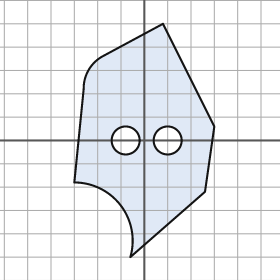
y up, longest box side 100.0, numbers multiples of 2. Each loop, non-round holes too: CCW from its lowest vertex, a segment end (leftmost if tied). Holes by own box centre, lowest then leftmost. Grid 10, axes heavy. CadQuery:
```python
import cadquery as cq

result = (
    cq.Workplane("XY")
    .moveTo(-6.0, -50.0)
    .lineTo(26.0, -22.0)
    .lineTo(30.0, 6.0)
    .lineTo(8.0, 50.0)
    .lineTo(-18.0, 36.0)
    .threePointArc((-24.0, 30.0), (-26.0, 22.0))
    .lineTo(-30.0, -18.0)
    .threePointArc((-10.0, -28.0), (-6.0, -50.0))
    .close()
    .moveTo(-8.0, 0.0)
    .circle(6.0)
    .moveTo(10.0, 0.0)
    .circle(6.0)
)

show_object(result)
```